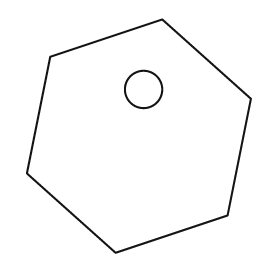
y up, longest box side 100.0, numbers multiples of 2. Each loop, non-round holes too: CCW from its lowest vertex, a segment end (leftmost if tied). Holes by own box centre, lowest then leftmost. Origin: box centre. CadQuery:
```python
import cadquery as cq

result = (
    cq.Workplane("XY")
    .moveTo(-10.0, -50.0)
    .lineTo(38.0, -34.0)
    .lineTo(48.0, 16.0)
    .lineTo(10.0, 50.0)
    .lineTo(-38.0, 34.0)
    .lineTo(-48.0, -16.0)
    .close()
    .moveTo(2.0, 20.0)
    .circle(8.0)
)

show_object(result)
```